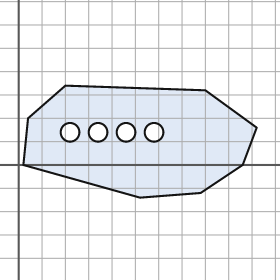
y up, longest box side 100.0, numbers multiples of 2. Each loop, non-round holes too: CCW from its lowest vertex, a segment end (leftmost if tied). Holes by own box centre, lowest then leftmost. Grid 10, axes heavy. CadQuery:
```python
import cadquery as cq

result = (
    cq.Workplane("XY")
    .moveTo(52.0, -14.0)
    .lineTo(78.0, -12.0)
    .lineTo(96.0, 0.0)
    .lineTo(102.0, 16.0)
    .lineTo(80.0, 32.0)
    .lineTo(20.0, 34.0)
    .lineTo(4.0, 20.0)
    .lineTo(2.0, 0.0)
    .close()
    .moveTo(22.0, 14.0)
    .circle(4.0)
    .moveTo(34.0, 14.0)
    .circle(4.0)
    .moveTo(46.0, 14.0)
    .circle(4.0)
    .moveTo(58.0, 14.0)
    .circle(4.0)
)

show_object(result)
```